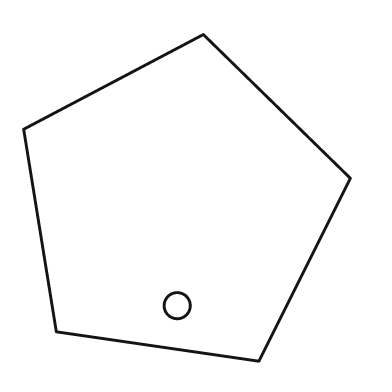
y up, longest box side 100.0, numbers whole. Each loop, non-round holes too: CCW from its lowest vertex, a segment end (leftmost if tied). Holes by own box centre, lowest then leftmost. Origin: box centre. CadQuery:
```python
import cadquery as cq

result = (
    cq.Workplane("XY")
    .moveTo(22.0, -50.0)
    .lineTo(50.0, 6.0)
    .lineTo(5.0, 50.0)
    .lineTo(-50.0, 21.0)
    .lineTo(-40.0, -41.0)
    .close()
    .moveTo(-3.0, -33.0)
    .circle(4.0)
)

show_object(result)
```